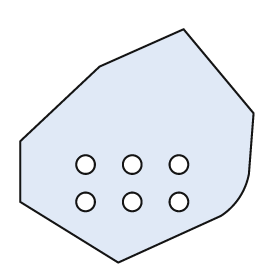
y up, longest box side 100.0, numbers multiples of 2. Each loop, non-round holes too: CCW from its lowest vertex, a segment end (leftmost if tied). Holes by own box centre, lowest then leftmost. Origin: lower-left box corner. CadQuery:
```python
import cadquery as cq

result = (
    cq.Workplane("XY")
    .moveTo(42.0, 0.0)
    .lineTo(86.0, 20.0)
    .threePointArc((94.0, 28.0), (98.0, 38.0))
    .lineTo(100.0, 64.0)
    .lineTo(70.0, 100.0)
    .lineTo(34.0, 84.0)
    .lineTo(0.0, 52.0)
    .lineTo(0.0, 26.0)
    .close()
    .moveTo(28.0, 26.0)
    .circle(4.0)
    .moveTo(48.0, 26.0)
    .circle(4.0)
    .moveTo(68.0, 26.0)
    .circle(4.0)
    .moveTo(28.0, 42.0)
    .circle(4.0)
    .moveTo(48.0, 42.0)
    .circle(4.0)
    .moveTo(68.0, 42.0)
    .circle(4.0)
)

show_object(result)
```